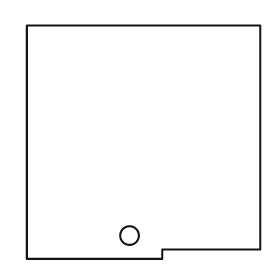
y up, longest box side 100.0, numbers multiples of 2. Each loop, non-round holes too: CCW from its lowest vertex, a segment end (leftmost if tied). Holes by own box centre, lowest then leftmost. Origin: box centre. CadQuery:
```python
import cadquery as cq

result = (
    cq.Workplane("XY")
    .moveTo(-50.0, -50.0)
    .lineTo(8.0, -50.0)
    .lineTo(8.0, -46.0)
    .lineTo(50.0, -46.0)
    .lineTo(50.0, 50.0)
    .lineTo(-50.0, 50.0)
    .close()
    .moveTo(-6.0, -40.0)
    .circle(4.0)
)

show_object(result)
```